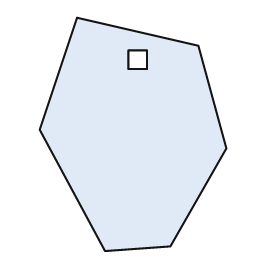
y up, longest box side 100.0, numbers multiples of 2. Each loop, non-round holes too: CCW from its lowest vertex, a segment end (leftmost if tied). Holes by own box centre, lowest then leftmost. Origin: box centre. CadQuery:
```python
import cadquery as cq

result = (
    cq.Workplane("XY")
    .moveTo(-12.0, -50.0)
    .lineTo(16.0, -48.0)
    .lineTo(40.0, -6.0)
    .lineTo(28.0, 38.0)
    .lineTo(-24.0, 50.0)
    .lineTo(-40.0, 2.0)
    .close()
    .moveTo(-2.0, 28.0)
    .lineTo(6.0, 28.0)
    .lineTo(6.0, 36.0)
    .lineTo(-2.0, 36.0)
    .close()
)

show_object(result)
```